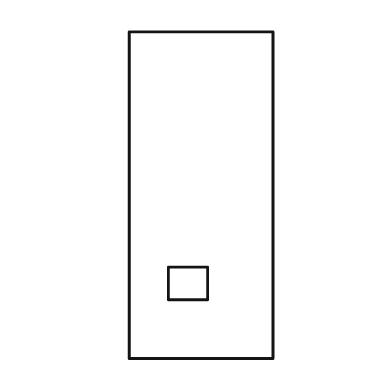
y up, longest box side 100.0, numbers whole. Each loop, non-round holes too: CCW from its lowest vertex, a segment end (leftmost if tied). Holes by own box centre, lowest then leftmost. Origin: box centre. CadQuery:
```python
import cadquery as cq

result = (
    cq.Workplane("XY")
    .moveTo(-22.0, -50.0)
    .lineTo(22.0, -50.0)
    .lineTo(22.0, 50.0)
    .lineTo(-22.0, 50.0)
    .close()
    .moveTo(-10.0, -32.0)
    .lineTo(2.0, -32.0)
    .lineTo(2.0, -22.0)
    .lineTo(-10.0, -22.0)
    .close()
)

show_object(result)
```